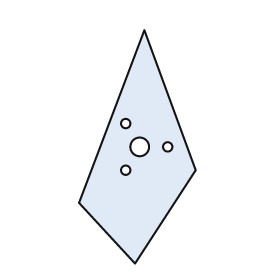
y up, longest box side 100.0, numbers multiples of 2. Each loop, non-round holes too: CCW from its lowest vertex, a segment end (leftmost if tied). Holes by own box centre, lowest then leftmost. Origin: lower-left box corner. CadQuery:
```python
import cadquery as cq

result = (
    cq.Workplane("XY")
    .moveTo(24.0, 0.0)
    .lineTo(50.0, 40.0)
    .lineTo(28.0, 100.0)
    .lineTo(0.0, 26.0)
    .close()
    .moveTo(20.0, 40.0)
    .circle(2.0)
    .moveTo(26.0, 50.0)
    .circle(4.0)
    .moveTo(38.0, 50.0)
    .circle(2.0)
    .moveTo(20.0, 60.0)
    .circle(2.0)
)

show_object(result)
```